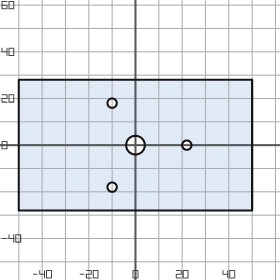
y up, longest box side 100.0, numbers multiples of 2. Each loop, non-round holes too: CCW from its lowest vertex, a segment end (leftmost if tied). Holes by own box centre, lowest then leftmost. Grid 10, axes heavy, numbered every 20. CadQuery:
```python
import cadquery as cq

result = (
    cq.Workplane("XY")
    .moveTo(-50.0, -28.0)
    .lineTo(50.0, -28.0)
    .lineTo(50.0, 28.0)
    .lineTo(-50.0, 28.0)
    .close()
    .moveTo(-10.0, -18.0)
    .circle(2.0)
    .moveTo(0.0, 0.0)
    .circle(4.0)
    .moveTo(22.0, 0.0)
    .circle(2.0)
    .moveTo(-10.0, 18.0)
    .circle(2.0)
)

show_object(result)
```